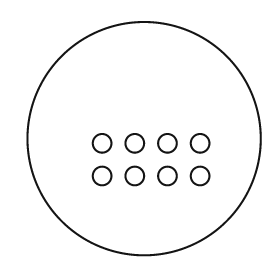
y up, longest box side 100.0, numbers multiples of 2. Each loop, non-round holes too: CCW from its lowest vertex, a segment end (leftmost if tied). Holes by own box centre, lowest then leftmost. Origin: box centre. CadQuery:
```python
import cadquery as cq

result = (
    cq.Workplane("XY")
    .moveTo(0.0, 0.0)
    .circle(50.0)
    .moveTo(-18.0, -16.0)
    .circle(4.0)
    .moveTo(-4.0, -16.0)
    .circle(4.0)
    .moveTo(10.0, -16.0)
    .circle(4.0)
    .moveTo(24.0, -16.0)
    .circle(4.0)
    .moveTo(-18.0, -2.0)
    .circle(4.0)
    .moveTo(-4.0, -2.0)
    .circle(4.0)
    .moveTo(10.0, -2.0)
    .circle(4.0)
    .moveTo(24.0, -2.0)
    .circle(4.0)
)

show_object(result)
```